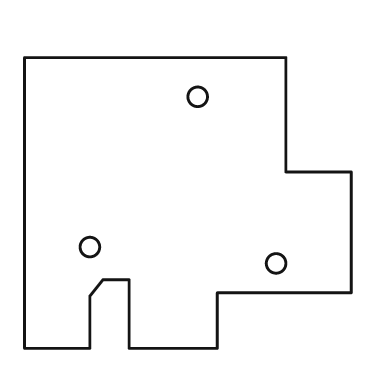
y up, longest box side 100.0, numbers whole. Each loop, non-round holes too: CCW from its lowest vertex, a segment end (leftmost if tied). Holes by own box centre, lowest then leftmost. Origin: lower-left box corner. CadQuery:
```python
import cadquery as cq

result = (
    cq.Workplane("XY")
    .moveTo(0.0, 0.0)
    .lineTo(20.0, 0.0)
    .lineTo(20.0, 16.0)
    .lineTo(24.0, 21.0)
    .lineTo(32.0, 21.0)
    .lineTo(32.0, 0.0)
    .lineTo(59.0, 0.0)
    .lineTo(59.0, 17.0)
    .lineTo(100.0, 17.0)
    .lineTo(100.0, 54.0)
    .lineTo(80.0, 54.0)
    .lineTo(80.0, 89.0)
    .lineTo(0.0, 89.0)
    .close()
    .moveTo(77.0, 26.0)
    .circle(3.0)
    .moveTo(20.0, 31.0)
    .circle(3.0)
    .moveTo(53.0, 77.0)
    .circle(3.0)
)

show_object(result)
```